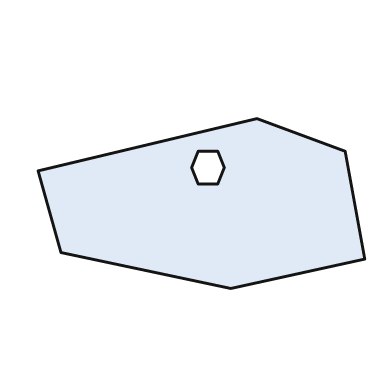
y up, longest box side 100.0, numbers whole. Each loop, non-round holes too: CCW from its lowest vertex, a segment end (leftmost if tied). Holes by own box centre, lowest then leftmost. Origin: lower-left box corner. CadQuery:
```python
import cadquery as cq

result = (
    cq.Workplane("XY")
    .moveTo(59.0, 0.0)
    .lineTo(100.0, 9.0)
    .lineTo(94.0, 42.0)
    .lineTo(67.0, 52.0)
    .lineTo(0.0, 36.0)
    .lineTo(7.0, 11.0)
    .close()
    .moveTo(49.0, 32.0)
    .lineTo(55.0, 32.0)
    .lineTo(57.0, 37.0)
    .lineTo(55.0, 42.0)
    .lineTo(49.0, 42.0)
    .lineTo(47.0, 37.0)
    .close()
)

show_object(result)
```